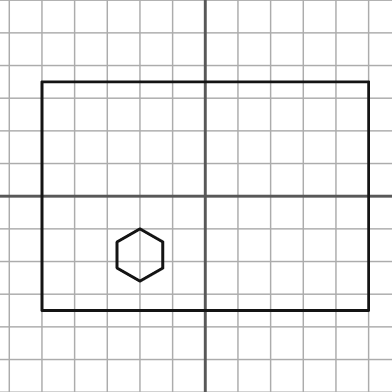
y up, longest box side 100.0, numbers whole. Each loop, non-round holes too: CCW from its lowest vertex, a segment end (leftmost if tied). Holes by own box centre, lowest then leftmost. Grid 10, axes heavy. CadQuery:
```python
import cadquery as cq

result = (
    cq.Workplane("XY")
    .moveTo(-50.0, -35.0)
    .lineTo(50.0, -35.0)
    .lineTo(50.0, 35.0)
    .lineTo(-50.0, 35.0)
    .close()
    .moveTo(-20.0, -26.0)
    .lineTo(-13.0, -22.0)
    .lineTo(-13.0, -14.0)
    .lineTo(-20.0, -10.0)
    .lineTo(-27.0, -14.0)
    .lineTo(-27.0, -22.0)
    .close()
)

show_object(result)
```